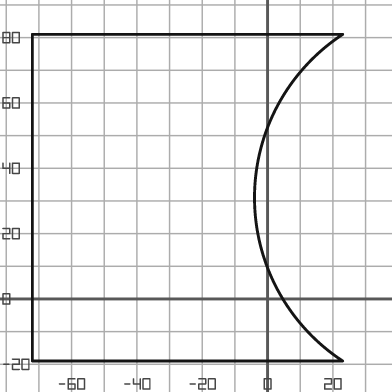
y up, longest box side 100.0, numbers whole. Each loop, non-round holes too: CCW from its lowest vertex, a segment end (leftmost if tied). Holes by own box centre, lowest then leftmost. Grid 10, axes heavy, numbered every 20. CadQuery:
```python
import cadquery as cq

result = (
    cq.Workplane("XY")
    .moveTo(-72.0, -19.0)
    .lineTo(23.0, -19.0)
    .threePointArc((-4.0, 31.0), (23.0, 81.0))
    .lineTo(-72.0, 81.0)
    .close()
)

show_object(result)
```